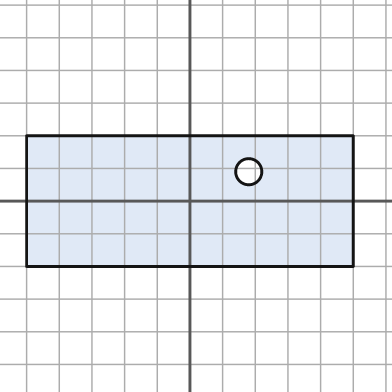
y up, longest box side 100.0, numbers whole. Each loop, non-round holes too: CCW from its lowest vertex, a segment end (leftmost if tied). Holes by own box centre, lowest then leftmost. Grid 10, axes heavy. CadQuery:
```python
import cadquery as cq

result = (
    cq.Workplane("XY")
    .moveTo(-50.0, -20.0)
    .lineTo(50.0, -20.0)
    .lineTo(50.0, 20.0)
    .lineTo(-50.0, 20.0)
    .close()
    .moveTo(18.0, 9.0)
    .circle(4.0)
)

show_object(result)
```